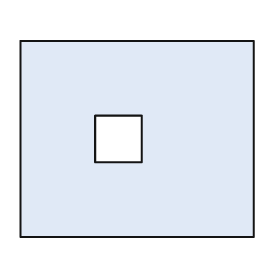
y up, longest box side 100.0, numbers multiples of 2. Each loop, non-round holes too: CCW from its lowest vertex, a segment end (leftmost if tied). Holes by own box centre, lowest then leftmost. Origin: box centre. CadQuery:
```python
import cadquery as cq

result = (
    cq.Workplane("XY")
    .moveTo(-50.0, -42.0)
    .lineTo(50.0, -42.0)
    .lineTo(50.0, 42.0)
    .lineTo(-50.0, 42.0)
    .close()
    .moveTo(-18.0, -10.0)
    .lineTo(2.0, -10.0)
    .lineTo(2.0, 10.0)
    .lineTo(-18.0, 10.0)
    .close()
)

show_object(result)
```